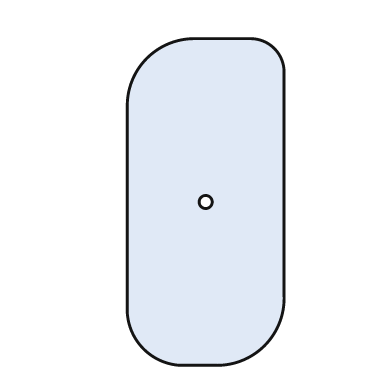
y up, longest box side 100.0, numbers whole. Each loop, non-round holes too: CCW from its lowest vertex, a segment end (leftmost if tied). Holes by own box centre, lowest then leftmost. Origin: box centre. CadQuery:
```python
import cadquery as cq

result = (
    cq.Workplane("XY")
    .moveTo(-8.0, -50.0)
    .lineTo(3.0, -50.0)
    .threePointArc((18.0, -44.0), (24.0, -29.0))
    .lineTo(24.0, 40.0)
    .threePointArc((21.0, 47.0), (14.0, 50.0))
    .lineTo(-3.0, 50.0)
    .threePointArc((-18.0, 44.0), (-24.0, 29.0))
    .lineTo(-24.0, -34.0)
    .threePointArc((-19.0, -45.0), (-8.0, -50.0))
    .close()
    .moveTo(0.0, 0.0)
    .circle(2.0)
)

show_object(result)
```